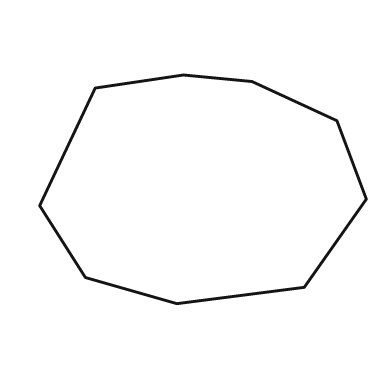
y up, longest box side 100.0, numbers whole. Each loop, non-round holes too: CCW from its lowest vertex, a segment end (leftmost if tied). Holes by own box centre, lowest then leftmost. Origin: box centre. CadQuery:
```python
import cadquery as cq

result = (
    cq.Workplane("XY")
    .moveTo(-8.0, -35.0)
    .lineTo(31.0, -30.0)
    .lineTo(50.0, -3.0)
    .lineTo(41.0, 21.0)
    .lineTo(15.0, 33.0)
    .lineTo(-6.0, 35.0)
    .lineTo(-33.0, 31.0)
    .lineTo(-50.0, -5.0)
    .lineTo(-36.0, -27.0)
    .close()
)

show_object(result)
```